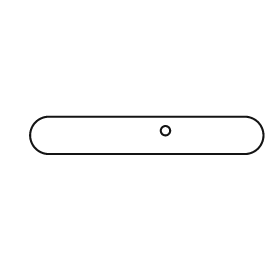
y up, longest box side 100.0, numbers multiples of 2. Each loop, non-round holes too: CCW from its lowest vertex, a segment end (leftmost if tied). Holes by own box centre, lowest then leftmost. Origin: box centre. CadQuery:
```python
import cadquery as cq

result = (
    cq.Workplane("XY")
    .moveTo(-42.0, -8.0)
    .lineTo(42.0, -8.0)
    .threePointArc((50.0, 0.0), (42.0, 8.0))
    .lineTo(-42.0, 8.0)
    .threePointArc((-50.0, 0.0), (-42.0, -8.0))
    .close()
    .moveTo(8.0, 2.0)
    .circle(2.0)
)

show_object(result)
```